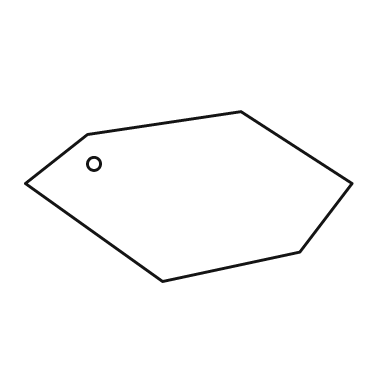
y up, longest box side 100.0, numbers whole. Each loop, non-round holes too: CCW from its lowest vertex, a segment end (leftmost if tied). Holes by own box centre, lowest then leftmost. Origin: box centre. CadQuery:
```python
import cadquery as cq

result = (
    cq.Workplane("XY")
    .moveTo(-8.0, -26.0)
    .lineTo(34.0, -17.0)
    .lineTo(50.0, 4.0)
    .lineTo(16.0, 26.0)
    .lineTo(-31.0, 19.0)
    .lineTo(-50.0, 4.0)
    .close()
    .moveTo(-29.0, 10.0)
    .circle(2.0)
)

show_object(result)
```